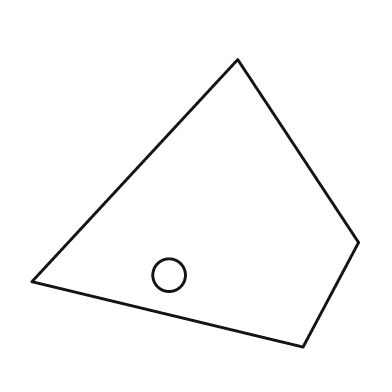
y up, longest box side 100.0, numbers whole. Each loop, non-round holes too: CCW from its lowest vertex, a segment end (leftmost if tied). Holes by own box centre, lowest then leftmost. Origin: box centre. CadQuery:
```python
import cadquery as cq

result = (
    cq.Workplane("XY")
    .moveTo(33.0, -44.0)
    .lineTo(50.0, -12.0)
    .lineTo(13.0, 44.0)
    .lineTo(-50.0, -24.0)
    .close()
    .moveTo(-8.0, -22.0)
    .circle(5.0)
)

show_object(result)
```